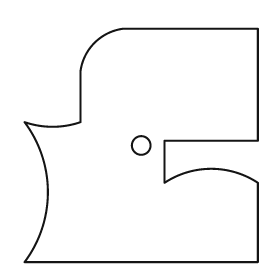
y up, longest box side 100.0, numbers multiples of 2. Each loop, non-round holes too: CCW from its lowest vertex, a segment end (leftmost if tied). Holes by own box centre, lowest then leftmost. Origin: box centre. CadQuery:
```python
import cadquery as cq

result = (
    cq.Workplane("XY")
    .moveTo(-50.0, -50.0)
    .lineTo(50.0, -50.0)
    .lineTo(50.0, -16.0)
    .threePointArc((30.0, -10.0), (10.0, -16.0))
    .lineTo(10.0, 2.0)
    .lineTo(50.0, 2.0)
    .lineTo(50.0, 50.0)
    .lineTo(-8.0, 50.0)
    .threePointArc((-20.0, 44.0), (-26.0, 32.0))
    .lineTo(-26.0, 10.0)
    .threePointArc((-38.0, 8.0), (-50.0, 10.0))
    .threePointArc((-40.0, -20.0), (-50.0, -50.0))
    .close()
    .moveTo(0.0, 0.0)
    .circle(4.0)
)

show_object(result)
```